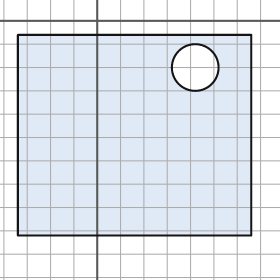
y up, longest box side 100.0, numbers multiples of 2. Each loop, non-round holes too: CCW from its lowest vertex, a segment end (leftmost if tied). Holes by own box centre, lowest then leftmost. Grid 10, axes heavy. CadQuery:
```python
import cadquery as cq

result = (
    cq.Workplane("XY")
    .moveTo(-34.0, -92.0)
    .lineTo(66.0, -92.0)
    .lineTo(66.0, -6.0)
    .lineTo(-34.0, -6.0)
    .close()
    .moveTo(42.0, -20.0)
    .circle(10.0)
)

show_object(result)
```